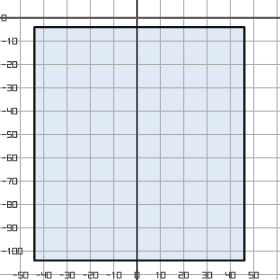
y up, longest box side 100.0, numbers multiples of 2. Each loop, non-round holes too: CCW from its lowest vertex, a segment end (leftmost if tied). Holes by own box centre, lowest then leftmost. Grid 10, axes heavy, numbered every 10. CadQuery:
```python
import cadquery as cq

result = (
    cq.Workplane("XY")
    .moveTo(-44.0, -104.0)
    .lineTo(46.0, -104.0)
    .lineTo(46.0, -4.0)
    .lineTo(-44.0, -4.0)
    .close()
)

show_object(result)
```